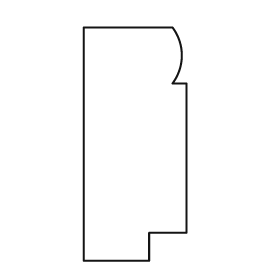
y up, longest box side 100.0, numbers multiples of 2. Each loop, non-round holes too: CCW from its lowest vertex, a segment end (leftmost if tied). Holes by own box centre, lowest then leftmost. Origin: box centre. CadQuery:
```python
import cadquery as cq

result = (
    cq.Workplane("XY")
    .moveTo(-22.0, -50.0)
    .lineTo(6.0, -50.0)
    .lineTo(6.0, -38.0)
    .lineTo(22.0, -38.0)
    .lineTo(22.0, 26.0)
    .lineTo(16.0, 26.0)
    .threePointArc((20.0, 38.0), (16.0, 50.0))
    .lineTo(-22.0, 50.0)
    .close()
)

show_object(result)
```